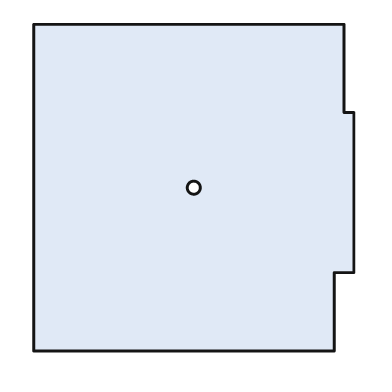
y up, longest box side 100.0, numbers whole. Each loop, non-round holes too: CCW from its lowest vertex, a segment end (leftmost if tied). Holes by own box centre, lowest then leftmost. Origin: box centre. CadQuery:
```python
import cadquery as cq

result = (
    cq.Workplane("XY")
    .moveTo(-49.0, -50.0)
    .lineTo(43.0, -50.0)
    .lineTo(43.0, -26.0)
    .lineTo(49.0, -26.0)
    .lineTo(49.0, 23.0)
    .lineTo(46.0, 23.0)
    .lineTo(46.0, 50.0)
    .lineTo(-49.0, 50.0)
    .close()
    .moveTo(0.0, 0.0)
    .circle(2.0)
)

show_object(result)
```